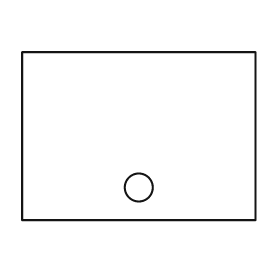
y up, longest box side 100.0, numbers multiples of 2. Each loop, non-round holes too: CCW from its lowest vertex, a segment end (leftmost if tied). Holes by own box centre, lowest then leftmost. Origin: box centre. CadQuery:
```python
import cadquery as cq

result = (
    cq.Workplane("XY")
    .moveTo(-50.0, -36.0)
    .lineTo(50.0, -36.0)
    .lineTo(50.0, 36.0)
    .lineTo(-50.0, 36.0)
    .close()
    .moveTo(0.0, -22.0)
    .circle(6.0)
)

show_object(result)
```